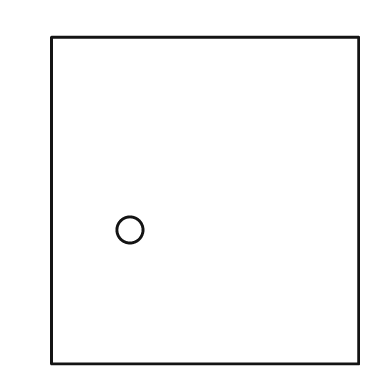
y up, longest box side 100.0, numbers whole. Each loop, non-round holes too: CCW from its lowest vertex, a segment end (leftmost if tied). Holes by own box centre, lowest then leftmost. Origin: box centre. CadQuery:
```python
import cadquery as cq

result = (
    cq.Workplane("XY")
    .moveTo(-47.0, -50.0)
    .lineTo(47.0, -50.0)
    .lineTo(47.0, 50.0)
    .lineTo(-47.0, 50.0)
    .close()
    .moveTo(-23.0, -9.0)
    .circle(4.0)
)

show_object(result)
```